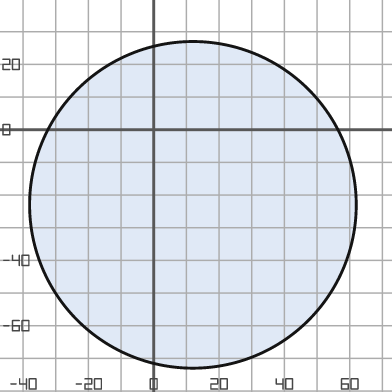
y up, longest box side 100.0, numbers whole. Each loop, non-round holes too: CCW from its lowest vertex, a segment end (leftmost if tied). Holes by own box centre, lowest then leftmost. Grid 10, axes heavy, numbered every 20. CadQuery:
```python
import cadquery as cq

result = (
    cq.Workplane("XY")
    .moveTo(12.0, -23.0)
    .circle(50.0)
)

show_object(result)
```